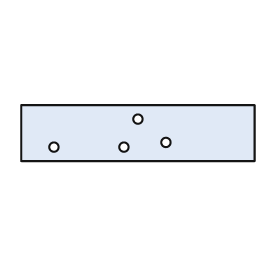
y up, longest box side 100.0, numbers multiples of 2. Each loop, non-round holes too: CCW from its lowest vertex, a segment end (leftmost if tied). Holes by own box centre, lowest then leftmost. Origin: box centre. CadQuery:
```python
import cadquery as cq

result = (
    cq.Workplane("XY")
    .moveTo(-50.0, -12.0)
    .lineTo(50.0, -12.0)
    .lineTo(50.0, 12.0)
    .lineTo(-50.0, 12.0)
    .close()
    .moveTo(-36.0, -6.0)
    .circle(2.0)
    .moveTo(-6.0, -6.0)
    .circle(2.0)
    .moveTo(12.0, -4.0)
    .circle(2.0)
    .moveTo(0.0, 6.0)
    .circle(2.0)
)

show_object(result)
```